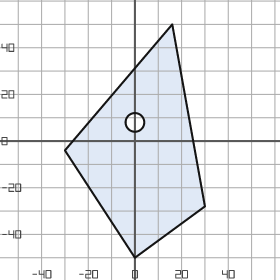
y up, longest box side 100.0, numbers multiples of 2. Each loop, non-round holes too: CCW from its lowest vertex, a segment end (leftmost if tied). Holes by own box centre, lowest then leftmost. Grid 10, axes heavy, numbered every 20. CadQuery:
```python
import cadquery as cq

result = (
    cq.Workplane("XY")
    .moveTo(0.0, -50.0)
    .lineTo(30.0, -28.0)
    .lineTo(16.0, 50.0)
    .lineTo(-30.0, -4.0)
    .close()
    .moveTo(0.0, 8.0)
    .circle(4.0)
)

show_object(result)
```